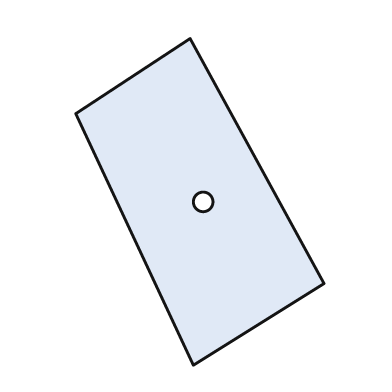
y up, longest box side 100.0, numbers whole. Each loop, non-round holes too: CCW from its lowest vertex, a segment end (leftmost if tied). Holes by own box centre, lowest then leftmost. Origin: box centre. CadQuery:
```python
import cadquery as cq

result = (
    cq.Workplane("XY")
    .moveTo(-2.0, -50.0)
    .lineTo(38.0, -25.0)
    .lineTo(-3.0, 50.0)
    .lineTo(-38.0, 27.0)
    .close()
    .moveTo(1.0, 0.0)
    .circle(3.0)
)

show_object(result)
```